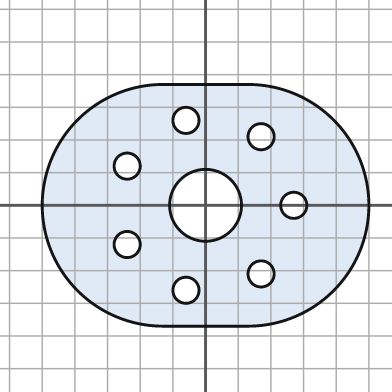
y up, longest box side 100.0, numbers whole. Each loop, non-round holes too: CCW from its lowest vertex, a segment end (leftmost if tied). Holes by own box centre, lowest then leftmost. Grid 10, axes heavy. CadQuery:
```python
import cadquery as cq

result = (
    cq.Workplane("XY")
    .moveTo(-13.0, -37.0)
    .lineTo(13.0, -37.0)
    .threePointArc((50.0, 0.0), (13.0, 37.0))
    .lineTo(-13.0, 37.0)
    .threePointArc((-50.0, 0.0), (-13.0, -37.0))
    .close()
    .moveTo(-6.0, -26.0)
    .circle(4.0)
    .moveTo(17.0, -21.0)
    .circle(4.0)
    .moveTo(-24.0, -12.0)
    .circle(4.0)
    .moveTo(0.0, 0.0)
    .circle(11.0)
    .moveTo(27.0, 0.0)
    .circle(4.0)
    .moveTo(-24.0, 12.0)
    .circle(4.0)
    .moveTo(17.0, 21.0)
    .circle(4.0)
    .moveTo(-6.0, 26.0)
    .circle(4.0)
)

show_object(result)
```